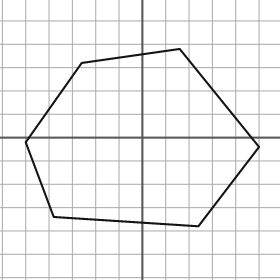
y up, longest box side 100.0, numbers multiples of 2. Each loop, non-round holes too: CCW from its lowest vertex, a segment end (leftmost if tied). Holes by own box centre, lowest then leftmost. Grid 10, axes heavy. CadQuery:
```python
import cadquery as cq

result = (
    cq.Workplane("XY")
    .moveTo(24.0, -38.0)
    .lineTo(50.0, -4.0)
    .lineTo(16.0, 38.0)
    .lineTo(-26.0, 32.0)
    .lineTo(-50.0, -2.0)
    .lineTo(-38.0, -34.0)
    .close()
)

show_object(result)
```